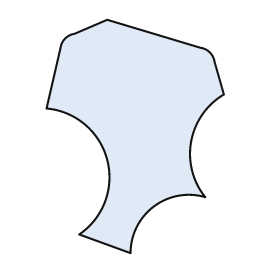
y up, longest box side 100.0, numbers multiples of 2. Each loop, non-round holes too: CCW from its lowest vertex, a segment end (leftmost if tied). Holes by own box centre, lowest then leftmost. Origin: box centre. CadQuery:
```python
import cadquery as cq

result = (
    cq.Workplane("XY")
    .moveTo(-2.0, -50.0)
    .threePointArc((8.0, -30.0), (30.0, -26.0))
    .threePointArc((24.0, -2.0), (38.0, 18.0))
    .lineTo(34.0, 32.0)
    .threePointArc((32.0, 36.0), (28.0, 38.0))
    .lineTo(-12.0, 50.0)
    .lineTo(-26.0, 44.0)
    .threePointArc((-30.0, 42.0), (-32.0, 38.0))
    .lineTo(-38.0, 12.0)
    .threePointArc((-12.0, -10.0), (-24.0, -42.0))
    .close()
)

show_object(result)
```